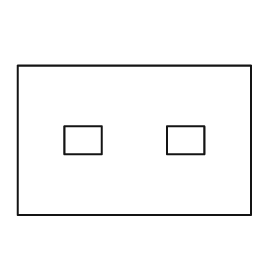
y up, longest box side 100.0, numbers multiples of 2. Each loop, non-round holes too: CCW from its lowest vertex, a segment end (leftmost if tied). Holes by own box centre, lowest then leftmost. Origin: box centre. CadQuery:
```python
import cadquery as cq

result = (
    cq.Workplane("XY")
    .moveTo(-50.0, -32.0)
    .lineTo(50.0, -32.0)
    .lineTo(50.0, 32.0)
    .lineTo(-50.0, 32.0)
    .close()
    .moveTo(-30.0, -6.0)
    .lineTo(-14.0, -6.0)
    .lineTo(-14.0, 6.0)
    .lineTo(-30.0, 6.0)
    .close()
    .moveTo(14.0, -6.0)
    .lineTo(30.0, -6.0)
    .lineTo(30.0, 6.0)
    .lineTo(14.0, 6.0)
    .close()
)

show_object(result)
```